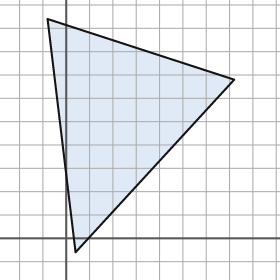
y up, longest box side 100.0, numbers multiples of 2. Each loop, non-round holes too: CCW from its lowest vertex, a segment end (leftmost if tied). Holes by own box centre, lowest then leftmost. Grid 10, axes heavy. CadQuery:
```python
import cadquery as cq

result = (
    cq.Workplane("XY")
    .moveTo(4.0, -6.0)
    .lineTo(72.0, 68.0)
    .lineTo(-8.0, 94.0)
    .close()
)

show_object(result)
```